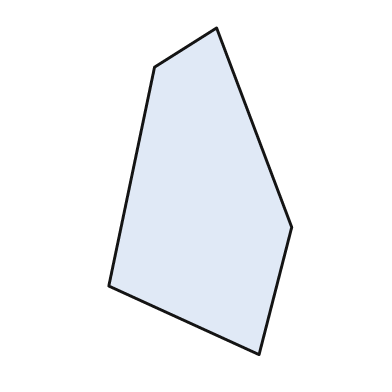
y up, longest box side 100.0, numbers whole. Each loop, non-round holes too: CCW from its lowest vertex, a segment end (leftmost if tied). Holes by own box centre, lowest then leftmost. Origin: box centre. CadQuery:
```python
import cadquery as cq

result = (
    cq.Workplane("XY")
    .moveTo(18.0, -50.0)
    .lineTo(28.0, -11.0)
    .lineTo(5.0, 50.0)
    .lineTo(-14.0, 38.0)
    .lineTo(-28.0, -29.0)
    .close()
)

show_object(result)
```